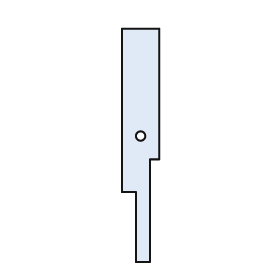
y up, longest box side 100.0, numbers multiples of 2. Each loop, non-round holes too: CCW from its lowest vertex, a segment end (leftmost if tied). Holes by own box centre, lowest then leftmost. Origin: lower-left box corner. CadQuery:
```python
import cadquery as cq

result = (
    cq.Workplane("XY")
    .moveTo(6.0, 0.0)
    .lineTo(12.0, 0.0)
    .lineTo(12.0, 44.0)
    .lineTo(16.0, 44.0)
    .lineTo(16.0, 100.0)
    .lineTo(0.0, 100.0)
    .lineTo(0.0, 30.0)
    .lineTo(6.0, 30.0)
    .close()
    .moveTo(8.0, 54.0)
    .circle(2.0)
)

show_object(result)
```